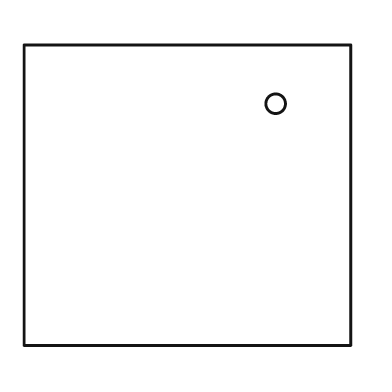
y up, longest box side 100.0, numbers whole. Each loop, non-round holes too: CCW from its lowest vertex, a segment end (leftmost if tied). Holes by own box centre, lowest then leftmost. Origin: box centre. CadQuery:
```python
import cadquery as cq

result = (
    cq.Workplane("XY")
    .moveTo(-50.0, -46.0)
    .lineTo(50.0, -46.0)
    .lineTo(50.0, 46.0)
    .lineTo(-50.0, 46.0)
    .close()
    .moveTo(27.0, 28.0)
    .circle(3.0)
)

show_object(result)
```